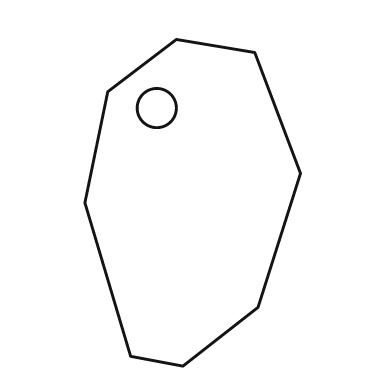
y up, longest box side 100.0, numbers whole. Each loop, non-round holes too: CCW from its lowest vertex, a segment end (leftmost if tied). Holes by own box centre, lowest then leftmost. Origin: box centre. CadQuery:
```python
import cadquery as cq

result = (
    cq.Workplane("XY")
    .moveTo(-3.0, -50.0)
    .lineTo(20.0, -32.0)
    .lineTo(33.0, 9.0)
    .lineTo(19.0, 46.0)
    .lineTo(-5.0, 50.0)
    .lineTo(-26.0, 34.0)
    .lineTo(-33.0, 0.0)
    .lineTo(-19.0, -47.0)
    .close()
    .moveTo(-11.0, 29.0)
    .circle(6.0)
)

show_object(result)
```